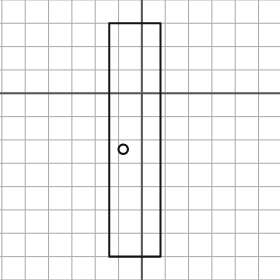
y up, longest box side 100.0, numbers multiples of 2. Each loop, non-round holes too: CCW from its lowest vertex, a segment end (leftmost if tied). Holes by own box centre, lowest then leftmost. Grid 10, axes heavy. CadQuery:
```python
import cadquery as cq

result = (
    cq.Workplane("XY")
    .moveTo(-14.0, -70.0)
    .lineTo(8.0, -70.0)
    .lineTo(8.0, 30.0)
    .lineTo(-14.0, 30.0)
    .close()
    .moveTo(-8.0, -24.0)
    .circle(2.0)
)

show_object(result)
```